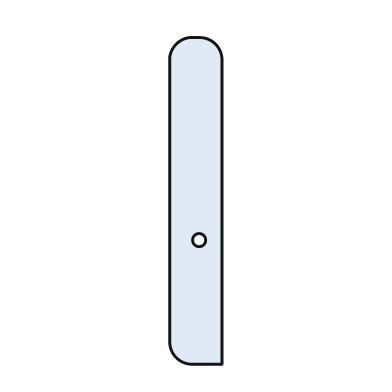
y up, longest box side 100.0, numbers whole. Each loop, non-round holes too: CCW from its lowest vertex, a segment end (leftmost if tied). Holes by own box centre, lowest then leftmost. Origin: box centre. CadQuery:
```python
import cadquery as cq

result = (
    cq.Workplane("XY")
    .moveTo(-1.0, -50.0)
    .lineTo(8.0, -50.0)
    .lineTo(8.0, 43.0)
    .threePointArc((6.0, 48.0), (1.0, 50.0))
    .lineTo(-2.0, 50.0)
    .threePointArc((-6.0, 48.0), (-8.0, 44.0))
    .lineTo(-8.0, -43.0)
    .threePointArc((-6.0, -48.0), (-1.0, -50.0))
    .close()
    .moveTo(1.0, -12.0)
    .circle(2.0)
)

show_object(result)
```